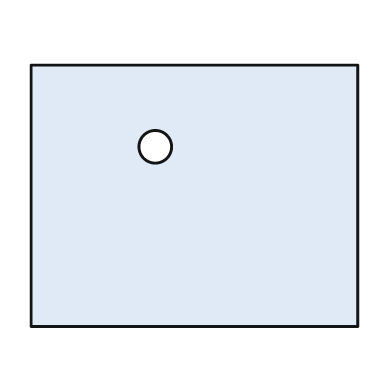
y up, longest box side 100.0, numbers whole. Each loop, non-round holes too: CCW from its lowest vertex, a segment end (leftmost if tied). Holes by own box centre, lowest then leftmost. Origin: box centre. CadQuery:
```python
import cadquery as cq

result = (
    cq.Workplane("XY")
    .moveTo(-50.0, -40.0)
    .lineTo(50.0, -40.0)
    .lineTo(50.0, 40.0)
    .lineTo(-50.0, 40.0)
    .close()
    .moveTo(-12.0, 15.0)
    .circle(5.0)
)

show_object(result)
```